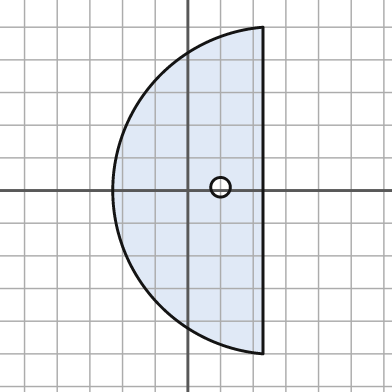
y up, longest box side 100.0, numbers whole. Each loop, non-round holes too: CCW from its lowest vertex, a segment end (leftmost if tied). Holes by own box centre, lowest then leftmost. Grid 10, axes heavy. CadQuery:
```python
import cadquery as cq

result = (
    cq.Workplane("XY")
    .moveTo(23.0, -50.0)
    .lineTo(23.0, 50.0)
    .threePointArc((-23.0, 0.0), (23.0, -50.0))
    .close()
    .moveTo(10.0, 1.0)
    .circle(3.0)
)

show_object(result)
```